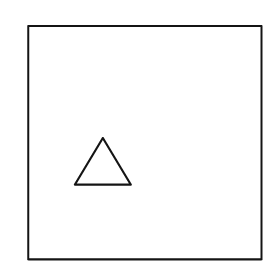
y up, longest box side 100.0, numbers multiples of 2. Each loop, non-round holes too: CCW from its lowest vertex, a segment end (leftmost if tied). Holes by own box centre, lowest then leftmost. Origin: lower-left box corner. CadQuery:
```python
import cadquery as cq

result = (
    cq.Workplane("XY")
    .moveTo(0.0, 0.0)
    .lineTo(100.0, 0.0)
    .lineTo(100.0, 100.0)
    .lineTo(0.0, 100.0)
    .close()
    .moveTo(20.0, 32.0)
    .lineTo(44.0, 32.0)
    .lineTo(32.0, 52.0)
    .close()
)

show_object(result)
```